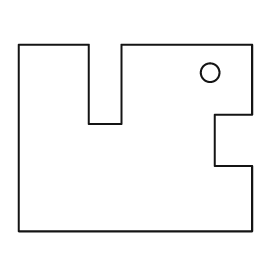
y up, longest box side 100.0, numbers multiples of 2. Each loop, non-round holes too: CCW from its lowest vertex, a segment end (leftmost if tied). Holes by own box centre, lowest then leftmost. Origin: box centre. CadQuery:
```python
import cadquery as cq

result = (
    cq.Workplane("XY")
    .moveTo(-50.0, -40.0)
    .lineTo(50.0, -40.0)
    .lineTo(50.0, -12.0)
    .lineTo(34.0, -12.0)
    .lineTo(34.0, 10.0)
    .lineTo(50.0, 10.0)
    .lineTo(50.0, 40.0)
    .lineTo(-6.0, 40.0)
    .lineTo(-6.0, 6.0)
    .lineTo(-20.0, 6.0)
    .lineTo(-20.0, 40.0)
    .lineTo(-50.0, 40.0)
    .close()
    .moveTo(32.0, 28.0)
    .circle(4.0)
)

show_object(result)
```